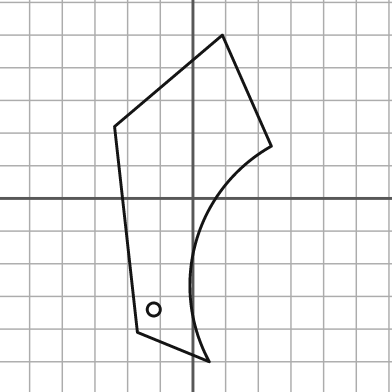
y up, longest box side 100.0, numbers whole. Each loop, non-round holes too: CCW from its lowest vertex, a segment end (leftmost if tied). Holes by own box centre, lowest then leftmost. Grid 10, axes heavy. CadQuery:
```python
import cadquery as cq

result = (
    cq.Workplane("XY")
    .moveTo(5.0, -50.0)
    .threePointArc((1.0, -13.0), (24.0, 16.0))
    .lineTo(9.0, 50.0)
    .lineTo(-24.0, 22.0)
    .lineTo(-17.0, -41.0)
    .close()
    .moveTo(-12.0, -34.0)
    .circle(2.0)
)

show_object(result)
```